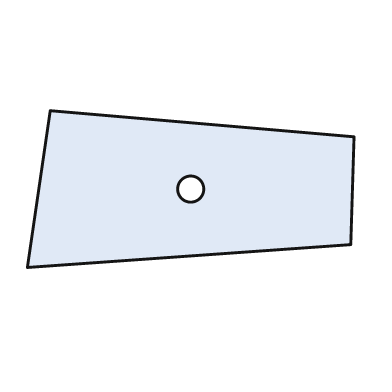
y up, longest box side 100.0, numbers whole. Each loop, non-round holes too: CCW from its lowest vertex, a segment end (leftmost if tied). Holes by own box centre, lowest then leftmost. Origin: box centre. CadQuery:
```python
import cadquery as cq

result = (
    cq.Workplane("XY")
    .moveTo(-50.0, -24.0)
    .lineTo(49.0, -17.0)
    .lineTo(50.0, 16.0)
    .lineTo(-43.0, 24.0)
    .close()
    .moveTo(0.0, 0.0)
    .circle(4.0)
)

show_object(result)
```